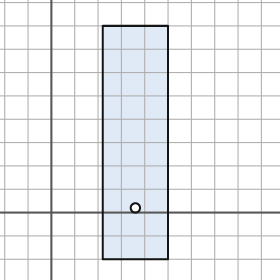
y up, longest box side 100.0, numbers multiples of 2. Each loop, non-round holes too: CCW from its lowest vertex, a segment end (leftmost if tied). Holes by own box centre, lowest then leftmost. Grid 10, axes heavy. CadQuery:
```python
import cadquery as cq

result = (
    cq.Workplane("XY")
    .moveTo(22.0, -20.0)
    .lineTo(50.0, -20.0)
    .lineTo(50.0, 80.0)
    .lineTo(22.0, 80.0)
    .close()
    .moveTo(36.0, 2.0)
    .circle(2.0)
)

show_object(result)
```